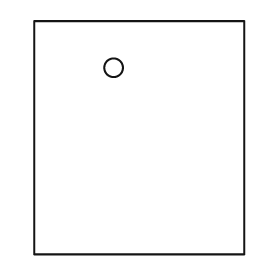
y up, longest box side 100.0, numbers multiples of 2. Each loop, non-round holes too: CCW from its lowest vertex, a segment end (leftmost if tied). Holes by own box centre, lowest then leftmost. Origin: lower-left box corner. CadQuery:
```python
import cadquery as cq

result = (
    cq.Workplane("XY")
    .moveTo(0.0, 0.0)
    .lineTo(90.0, 0.0)
    .lineTo(90.0, 100.0)
    .lineTo(0.0, 100.0)
    .close()
    .moveTo(34.0, 80.0)
    .circle(4.0)
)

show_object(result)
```